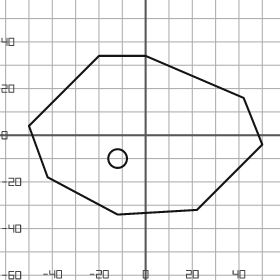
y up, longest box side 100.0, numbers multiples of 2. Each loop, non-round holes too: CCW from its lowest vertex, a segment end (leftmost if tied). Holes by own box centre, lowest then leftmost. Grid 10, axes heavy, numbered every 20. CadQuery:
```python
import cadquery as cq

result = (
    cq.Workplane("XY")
    .moveTo(-12.0, -34.0)
    .lineTo(22.0, -32.0)
    .lineTo(50.0, -4.0)
    .lineTo(42.0, 16.0)
    .lineTo(0.0, 34.0)
    .lineTo(-20.0, 34.0)
    .lineTo(-50.0, 4.0)
    .lineTo(-42.0, -18.0)
    .close()
    .moveTo(-12.0, -10.0)
    .circle(4.0)
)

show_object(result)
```